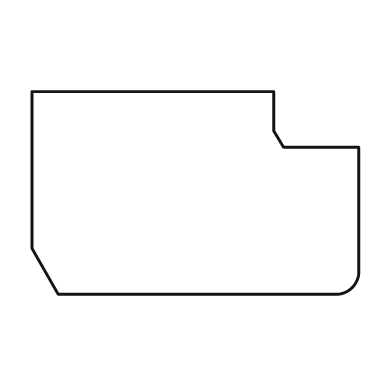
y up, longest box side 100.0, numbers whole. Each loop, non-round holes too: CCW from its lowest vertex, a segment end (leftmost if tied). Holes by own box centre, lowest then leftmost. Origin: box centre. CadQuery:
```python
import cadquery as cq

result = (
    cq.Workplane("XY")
    .moveTo(-42.0, -31.0)
    .lineTo(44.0, -31.0)
    .threePointArc((48.0, -29.0), (50.0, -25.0))
    .lineTo(50.0, 14.0)
    .lineTo(27.0, 14.0)
    .lineTo(24.0, 19.0)
    .lineTo(24.0, 31.0)
    .lineTo(-50.0, 31.0)
    .lineTo(-50.0, -17.0)
    .close()
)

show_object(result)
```